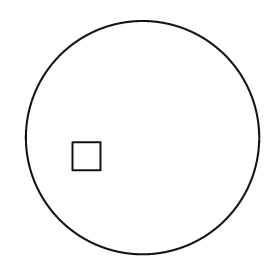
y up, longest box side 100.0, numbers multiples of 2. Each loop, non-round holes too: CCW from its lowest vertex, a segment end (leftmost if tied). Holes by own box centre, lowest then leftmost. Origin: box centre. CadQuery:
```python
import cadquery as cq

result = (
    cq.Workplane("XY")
    .moveTo(0.0, 0.0)
    .circle(50.0)
    .moveTo(-30.0, -14.0)
    .lineTo(-18.0, -14.0)
    .lineTo(-18.0, -2.0)
    .lineTo(-30.0, -2.0)
    .close()
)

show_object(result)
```